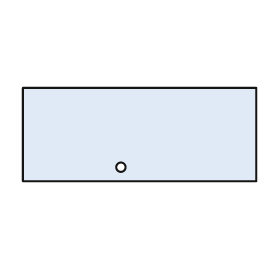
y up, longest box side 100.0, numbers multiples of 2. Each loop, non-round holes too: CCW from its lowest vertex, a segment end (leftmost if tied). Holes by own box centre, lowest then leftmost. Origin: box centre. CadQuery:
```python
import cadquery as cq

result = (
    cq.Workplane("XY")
    .moveTo(-50.0, -20.0)
    .lineTo(50.0, -20.0)
    .lineTo(50.0, 20.0)
    .lineTo(-50.0, 20.0)
    .close()
    .moveTo(-8.0, -14.0)
    .circle(2.0)
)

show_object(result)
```